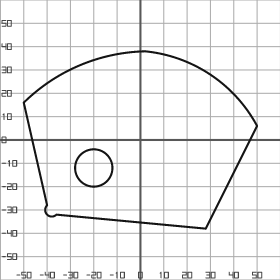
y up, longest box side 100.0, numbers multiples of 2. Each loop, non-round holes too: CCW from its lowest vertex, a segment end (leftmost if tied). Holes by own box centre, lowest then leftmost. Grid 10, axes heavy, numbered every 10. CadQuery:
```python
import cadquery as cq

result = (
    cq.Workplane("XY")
    .moveTo(28.0, -38.0)
    .lineTo(50.0, 6.0)
    .threePointArc((30.0, 28.0), (2.0, 38.0))
    .threePointArc((-26.0, 32.0), (-50.0, 16.0))
    .lineTo(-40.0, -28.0)
    .threePointArc((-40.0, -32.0), (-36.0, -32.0))
    .close()
    .moveTo(-20.0, -12.0)
    .circle(8.0)
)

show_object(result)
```